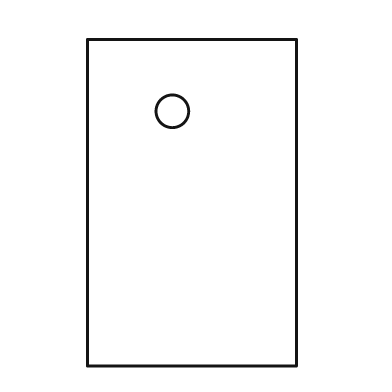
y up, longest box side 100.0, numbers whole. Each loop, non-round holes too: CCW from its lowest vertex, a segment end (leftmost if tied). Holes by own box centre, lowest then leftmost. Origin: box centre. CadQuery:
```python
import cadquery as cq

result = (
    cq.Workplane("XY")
    .moveTo(-32.0, -50.0)
    .lineTo(32.0, -50.0)
    .lineTo(32.0, 50.0)
    .lineTo(-32.0, 50.0)
    .close()
    .moveTo(-6.0, 28.0)
    .circle(5.0)
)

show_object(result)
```